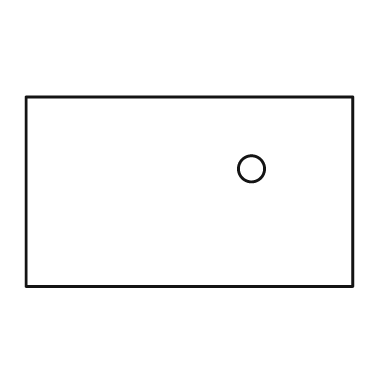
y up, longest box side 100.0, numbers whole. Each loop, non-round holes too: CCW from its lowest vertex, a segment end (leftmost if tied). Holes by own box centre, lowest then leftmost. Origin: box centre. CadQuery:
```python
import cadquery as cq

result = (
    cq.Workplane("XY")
    .moveTo(-50.0, -29.0)
    .lineTo(50.0, -29.0)
    .lineTo(50.0, 29.0)
    .lineTo(-50.0, 29.0)
    .close()
    .moveTo(19.0, 7.0)
    .circle(4.0)
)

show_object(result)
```